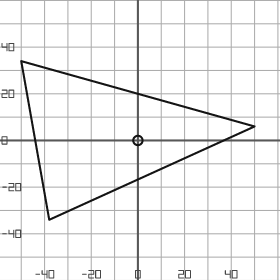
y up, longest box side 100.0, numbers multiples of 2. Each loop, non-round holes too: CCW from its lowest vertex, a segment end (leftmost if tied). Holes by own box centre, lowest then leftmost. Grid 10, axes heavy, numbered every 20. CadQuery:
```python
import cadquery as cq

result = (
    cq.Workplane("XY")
    .moveTo(-38.0, -34.0)
    .lineTo(50.0, 6.0)
    .lineTo(-50.0, 34.0)
    .close()
    .moveTo(0.0, 0.0)
    .circle(2.0)
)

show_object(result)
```